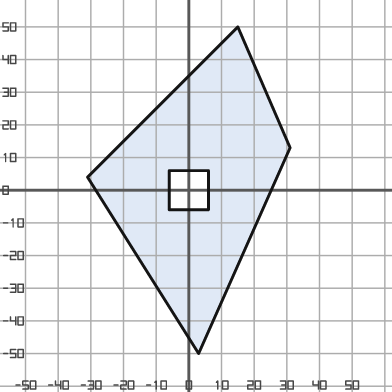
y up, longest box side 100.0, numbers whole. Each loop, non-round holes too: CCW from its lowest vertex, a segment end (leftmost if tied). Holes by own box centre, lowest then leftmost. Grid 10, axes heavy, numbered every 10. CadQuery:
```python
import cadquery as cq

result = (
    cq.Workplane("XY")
    .moveTo(3.0, -50.0)
    .lineTo(31.0, 13.0)
    .lineTo(15.0, 50.0)
    .lineTo(-31.0, 4.0)
    .close()
    .moveTo(-6.0, -6.0)
    .lineTo(6.0, -6.0)
    .lineTo(6.0, 6.0)
    .lineTo(-6.0, 6.0)
    .close()
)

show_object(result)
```